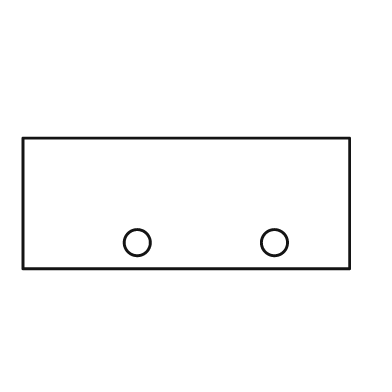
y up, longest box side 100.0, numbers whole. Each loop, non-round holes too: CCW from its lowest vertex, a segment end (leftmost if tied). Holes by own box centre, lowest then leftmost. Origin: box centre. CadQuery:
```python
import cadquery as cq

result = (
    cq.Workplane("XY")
    .moveTo(-50.0, -20.0)
    .lineTo(50.0, -20.0)
    .lineTo(50.0, 20.0)
    .lineTo(-50.0, 20.0)
    .close()
    .moveTo(-15.0, -12.0)
    .circle(4.0)
    .moveTo(27.0, -12.0)
    .circle(4.0)
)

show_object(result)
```